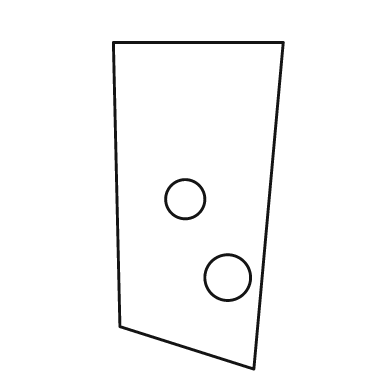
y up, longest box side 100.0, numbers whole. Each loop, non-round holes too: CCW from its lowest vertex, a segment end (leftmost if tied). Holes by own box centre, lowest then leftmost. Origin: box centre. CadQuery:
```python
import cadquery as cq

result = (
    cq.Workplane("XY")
    .moveTo(17.0, -50.0)
    .lineTo(26.0, 50.0)
    .lineTo(-26.0, 50.0)
    .lineTo(-24.0, -37.0)
    .close()
    .moveTo(9.0, -22.0)
    .circle(7.0)
    .moveTo(-4.0, 2.0)
    .circle(6.0)
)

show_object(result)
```